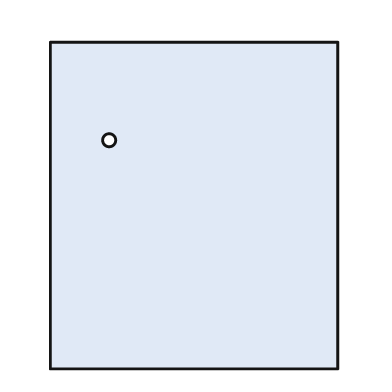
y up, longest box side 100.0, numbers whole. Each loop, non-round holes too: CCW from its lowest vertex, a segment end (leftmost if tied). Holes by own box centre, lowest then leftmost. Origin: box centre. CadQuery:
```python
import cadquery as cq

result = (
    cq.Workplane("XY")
    .moveTo(-44.0, -50.0)
    .lineTo(44.0, -50.0)
    .lineTo(44.0, 50.0)
    .lineTo(-44.0, 50.0)
    .close()
    .moveTo(-26.0, 20.0)
    .circle(2.0)
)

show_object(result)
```